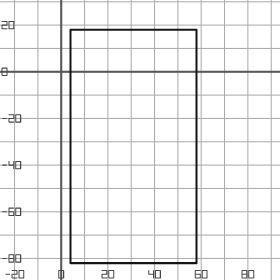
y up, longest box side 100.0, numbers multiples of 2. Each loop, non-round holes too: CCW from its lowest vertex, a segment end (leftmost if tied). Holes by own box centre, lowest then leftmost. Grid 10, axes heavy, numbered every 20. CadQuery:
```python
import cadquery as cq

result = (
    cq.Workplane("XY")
    .moveTo(4.0, -82.0)
    .lineTo(58.0, -82.0)
    .lineTo(58.0, 18.0)
    .lineTo(4.0, 18.0)
    .close()
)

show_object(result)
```